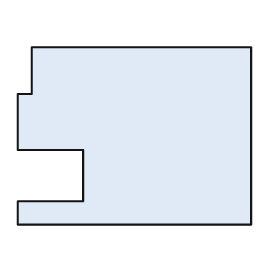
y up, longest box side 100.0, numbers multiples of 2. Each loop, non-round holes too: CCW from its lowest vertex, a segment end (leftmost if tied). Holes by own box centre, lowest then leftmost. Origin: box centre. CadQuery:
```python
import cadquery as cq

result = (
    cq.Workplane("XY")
    .moveTo(-50.0, -38.0)
    .lineTo(50.0, -38.0)
    .lineTo(50.0, 38.0)
    .lineTo(-44.0, 38.0)
    .lineTo(-44.0, 18.0)
    .lineTo(-50.0, 18.0)
    .lineTo(-50.0, -6.0)
    .lineTo(-22.0, -6.0)
    .lineTo(-22.0, -28.0)
    .lineTo(-50.0, -28.0)
    .close()
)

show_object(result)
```